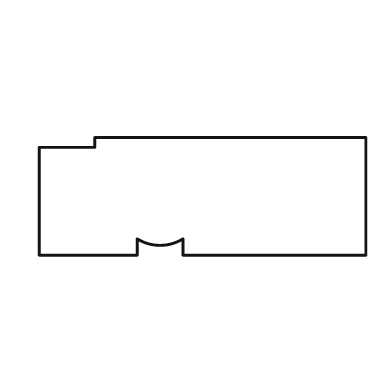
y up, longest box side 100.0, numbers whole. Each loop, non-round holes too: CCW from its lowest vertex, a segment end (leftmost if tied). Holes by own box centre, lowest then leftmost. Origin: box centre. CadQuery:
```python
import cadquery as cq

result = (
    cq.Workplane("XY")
    .moveTo(-50.0, -18.0)
    .lineTo(-20.0, -18.0)
    .lineTo(-20.0, -13.0)
    .threePointArc((-13.0, -15.0), (-6.0, -13.0))
    .lineTo(-6.0, -18.0)
    .lineTo(50.0, -18.0)
    .lineTo(50.0, 18.0)
    .lineTo(-33.0, 18.0)
    .lineTo(-33.0, 15.0)
    .lineTo(-50.0, 15.0)
    .close()
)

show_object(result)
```